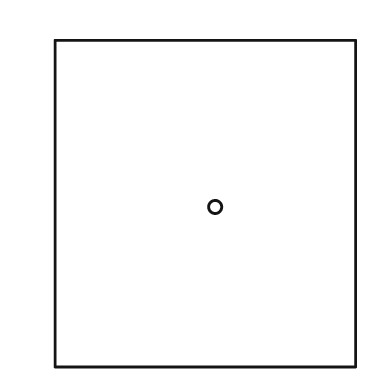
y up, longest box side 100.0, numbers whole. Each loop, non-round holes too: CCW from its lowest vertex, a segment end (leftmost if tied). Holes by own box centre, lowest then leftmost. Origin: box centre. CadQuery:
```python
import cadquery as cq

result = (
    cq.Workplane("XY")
    .moveTo(-46.0, -50.0)
    .lineTo(46.0, -50.0)
    .lineTo(46.0, 50.0)
    .lineTo(-46.0, 50.0)
    .close()
    .moveTo(3.0, -1.0)
    .circle(2.0)
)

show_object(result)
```